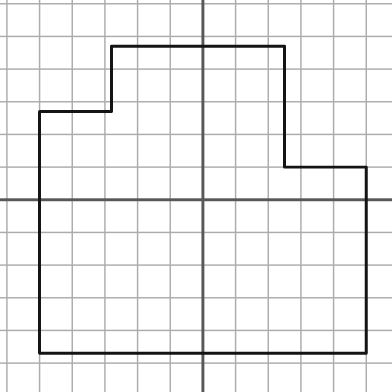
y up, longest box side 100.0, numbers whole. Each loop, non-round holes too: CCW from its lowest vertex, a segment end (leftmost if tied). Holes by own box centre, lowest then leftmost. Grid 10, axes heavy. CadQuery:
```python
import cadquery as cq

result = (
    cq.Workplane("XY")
    .moveTo(-50.0, -47.0)
    .lineTo(50.0, -47.0)
    .lineTo(50.0, 10.0)
    .lineTo(25.0, 10.0)
    .lineTo(25.0, 47.0)
    .lineTo(-28.0, 47.0)
    .lineTo(-28.0, 27.0)
    .lineTo(-50.0, 27.0)
    .close()
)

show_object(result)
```